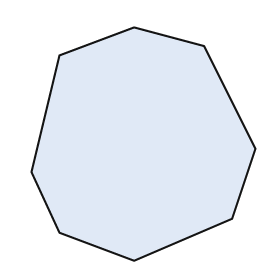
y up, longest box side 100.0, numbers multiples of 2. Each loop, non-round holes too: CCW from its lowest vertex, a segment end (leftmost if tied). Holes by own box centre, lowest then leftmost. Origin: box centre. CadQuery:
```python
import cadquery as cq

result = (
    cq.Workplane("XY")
    .moveTo(-4.0, -50.0)
    .lineTo(38.0, -32.0)
    .lineTo(48.0, -2.0)
    .lineTo(26.0, 42.0)
    .lineTo(-4.0, 50.0)
    .lineTo(-36.0, 38.0)
    .lineTo(-48.0, -12.0)
    .lineTo(-36.0, -38.0)
    .close()
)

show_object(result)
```